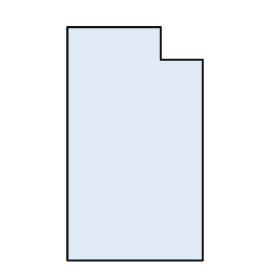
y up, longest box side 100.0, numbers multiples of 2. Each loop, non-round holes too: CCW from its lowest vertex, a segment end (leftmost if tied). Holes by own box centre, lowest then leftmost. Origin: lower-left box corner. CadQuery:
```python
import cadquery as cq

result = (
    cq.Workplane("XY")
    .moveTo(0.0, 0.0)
    .lineTo(58.0, 0.0)
    .lineTo(58.0, 86.0)
    .lineTo(40.0, 86.0)
    .lineTo(40.0, 100.0)
    .lineTo(0.0, 100.0)
    .close()
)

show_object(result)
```